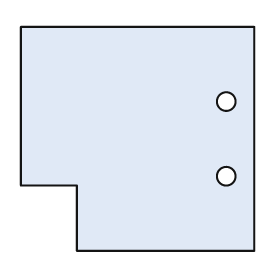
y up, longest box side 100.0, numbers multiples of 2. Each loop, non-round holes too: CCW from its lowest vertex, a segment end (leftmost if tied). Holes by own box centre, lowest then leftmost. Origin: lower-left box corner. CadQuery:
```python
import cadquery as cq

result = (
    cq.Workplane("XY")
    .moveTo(24.0, 0.0)
    .lineTo(100.0, 0.0)
    .lineTo(100.0, 96.0)
    .lineTo(0.0, 96.0)
    .lineTo(0.0, 28.0)
    .lineTo(24.0, 28.0)
    .close()
    .moveTo(88.0, 32.0)
    .circle(4.0)
    .moveTo(88.0, 64.0)
    .circle(4.0)
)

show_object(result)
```